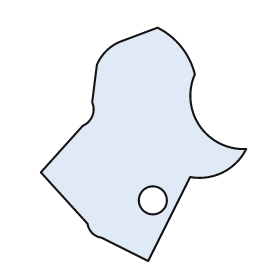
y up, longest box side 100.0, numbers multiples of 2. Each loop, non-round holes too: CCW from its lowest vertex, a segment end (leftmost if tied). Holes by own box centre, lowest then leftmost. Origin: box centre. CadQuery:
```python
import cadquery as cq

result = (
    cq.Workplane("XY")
    .moveTo(2.0, -50.0)
    .lineTo(20.0, -14.0)
    .threePointArc((34.0, -12.0), (44.0, -2.0))
    .threePointArc((24.0, 8.0), (22.0, 30.0))
    .threePointArc((16.0, 42.0), (6.0, 50.0))
    .lineTo(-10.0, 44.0)
    .threePointArc((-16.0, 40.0), (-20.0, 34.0))
    .lineTo(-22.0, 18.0)
    .threePointArc((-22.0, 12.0), (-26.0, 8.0))
    .lineTo(-44.0, -12.0)
    .lineTo(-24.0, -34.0)
    .threePointArc((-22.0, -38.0), (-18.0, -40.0))
    .close()
    .moveTo(4.0, -24.0)
    .circle(6.0)
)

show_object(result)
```